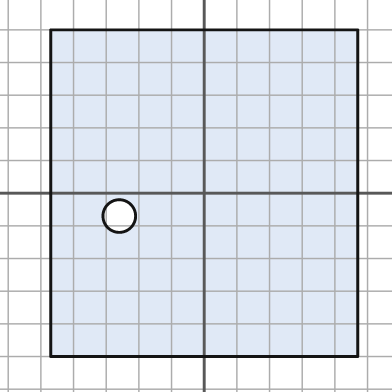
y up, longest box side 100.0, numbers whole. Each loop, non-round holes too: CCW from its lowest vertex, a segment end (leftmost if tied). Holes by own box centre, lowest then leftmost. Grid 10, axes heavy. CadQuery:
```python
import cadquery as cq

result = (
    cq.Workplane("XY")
    .moveTo(-47.0, -50.0)
    .lineTo(47.0, -50.0)
    .lineTo(47.0, 50.0)
    .lineTo(-47.0, 50.0)
    .close()
    .moveTo(-26.0, -7.0)
    .circle(5.0)
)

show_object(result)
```